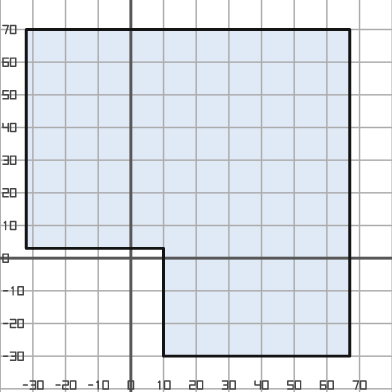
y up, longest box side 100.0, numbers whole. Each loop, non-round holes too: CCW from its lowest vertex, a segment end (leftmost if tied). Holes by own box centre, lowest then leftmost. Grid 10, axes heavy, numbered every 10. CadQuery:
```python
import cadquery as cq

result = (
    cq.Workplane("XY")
    .moveTo(10.0, -30.0)
    .lineTo(67.0, -30.0)
    .lineTo(67.0, 70.0)
    .lineTo(-32.0, 70.0)
    .lineTo(-32.0, 3.0)
    .lineTo(10.0, 3.0)
    .close()
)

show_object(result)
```